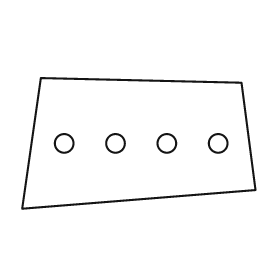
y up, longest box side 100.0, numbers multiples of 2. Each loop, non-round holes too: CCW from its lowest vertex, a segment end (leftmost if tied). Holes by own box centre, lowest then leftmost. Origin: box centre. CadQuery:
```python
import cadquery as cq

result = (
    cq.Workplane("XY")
    .moveTo(-50.0, -28.0)
    .lineTo(50.0, -20.0)
    .lineTo(44.0, 26.0)
    .lineTo(-42.0, 28.0)
    .close()
    .moveTo(-32.0, 0.0)
    .circle(4.0)
    .moveTo(-10.0, 0.0)
    .circle(4.0)
    .moveTo(12.0, 0.0)
    .circle(4.0)
    .moveTo(34.0, 0.0)
    .circle(4.0)
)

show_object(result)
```